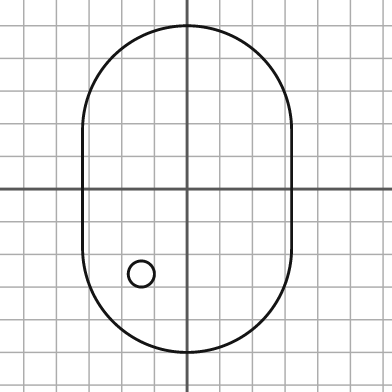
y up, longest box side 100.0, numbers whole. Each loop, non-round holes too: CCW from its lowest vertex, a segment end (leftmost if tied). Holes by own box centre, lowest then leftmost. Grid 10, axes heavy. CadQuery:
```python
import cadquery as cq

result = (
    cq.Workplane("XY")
    .moveTo(-32.0, -18.0)
    .threePointArc((0.0, -50.0), (32.0, -18.0))
    .lineTo(32.0, 18.0)
    .threePointArc((0.0, 50.0), (-32.0, 18.0))
    .close()
    .moveTo(-14.0, -26.0)
    .circle(4.0)
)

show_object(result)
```